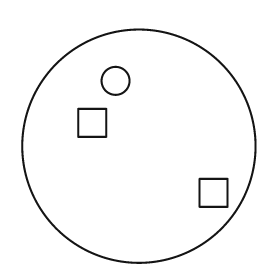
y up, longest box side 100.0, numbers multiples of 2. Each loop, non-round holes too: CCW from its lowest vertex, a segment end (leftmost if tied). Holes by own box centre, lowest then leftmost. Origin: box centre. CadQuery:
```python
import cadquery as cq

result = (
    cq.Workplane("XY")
    .moveTo(0.0, 0.0)
    .circle(50.0)
    .moveTo(26.0, -26.0)
    .lineTo(38.0, -26.0)
    .lineTo(38.0, -14.0)
    .lineTo(26.0, -14.0)
    .close()
    .moveTo(-26.0, 4.0)
    .lineTo(-14.0, 4.0)
    .lineTo(-14.0, 16.0)
    .lineTo(-26.0, 16.0)
    .close()
    .moveTo(-10.0, 28.0)
    .circle(6.0)
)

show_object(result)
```